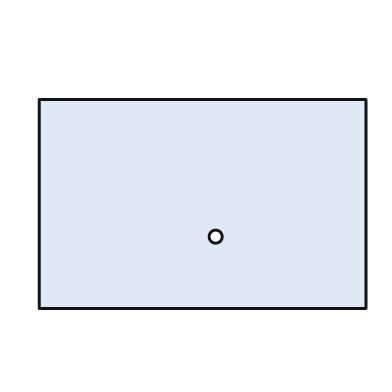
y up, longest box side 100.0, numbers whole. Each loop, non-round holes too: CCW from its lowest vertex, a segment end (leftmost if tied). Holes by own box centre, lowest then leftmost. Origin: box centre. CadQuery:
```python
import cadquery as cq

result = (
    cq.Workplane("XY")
    .moveTo(-50.0, -32.0)
    .lineTo(50.0, -32.0)
    .lineTo(50.0, 32.0)
    .lineTo(-50.0, 32.0)
    .close()
    .moveTo(4.0, -10.0)
    .circle(2.0)
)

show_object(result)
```